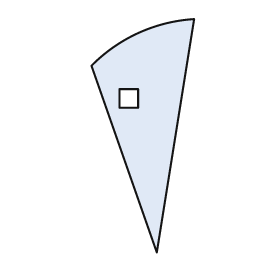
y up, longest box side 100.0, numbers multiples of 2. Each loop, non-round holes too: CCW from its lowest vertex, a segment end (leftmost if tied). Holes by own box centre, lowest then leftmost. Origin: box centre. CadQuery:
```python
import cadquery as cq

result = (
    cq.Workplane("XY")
    .moveTo(6.0, -50.0)
    .lineTo(22.0, 50.0)
    .threePointArc((-2.0, 44.0), (-22.0, 30.0))
    .close()
    .moveTo(-10.0, 12.0)
    .lineTo(-2.0, 12.0)
    .lineTo(-2.0, 20.0)
    .lineTo(-10.0, 20.0)
    .close()
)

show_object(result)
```